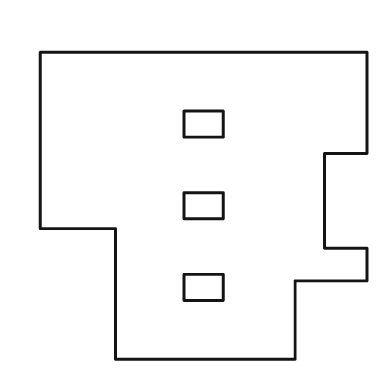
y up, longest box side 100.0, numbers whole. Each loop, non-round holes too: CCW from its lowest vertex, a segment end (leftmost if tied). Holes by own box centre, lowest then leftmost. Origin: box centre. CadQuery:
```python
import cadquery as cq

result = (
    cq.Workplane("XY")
    .moveTo(-27.0, -47.0)
    .lineTo(28.0, -47.0)
    .lineTo(28.0, -23.0)
    .lineTo(50.0, -23.0)
    .lineTo(50.0, -13.0)
    .lineTo(37.0, -13.0)
    .lineTo(37.0, 16.0)
    .lineTo(50.0, 16.0)
    .lineTo(50.0, 47.0)
    .lineTo(-50.0, 47.0)
    .lineTo(-50.0, -7.0)
    .lineTo(-27.0, -7.0)
    .close()
    .moveTo(-6.0, -29.0)
    .lineTo(6.0, -29.0)
    .lineTo(6.0, -21.0)
    .lineTo(-6.0, -21.0)
    .close()
    .moveTo(-6.0, -4.0)
    .lineTo(6.0, -4.0)
    .lineTo(6.0, 4.0)
    .lineTo(-6.0, 4.0)
    .close()
    .moveTo(-6.0, 21.0)
    .lineTo(6.0, 21.0)
    .lineTo(6.0, 29.0)
    .lineTo(-6.0, 29.0)
    .close()
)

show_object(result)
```